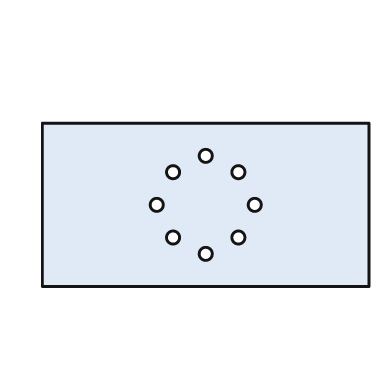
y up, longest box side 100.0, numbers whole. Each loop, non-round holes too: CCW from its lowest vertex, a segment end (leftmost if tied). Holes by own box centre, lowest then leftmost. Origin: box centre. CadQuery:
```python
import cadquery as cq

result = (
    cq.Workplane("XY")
    .moveTo(-50.0, -25.0)
    .lineTo(50.0, -25.0)
    .lineTo(50.0, 25.0)
    .lineTo(-50.0, 25.0)
    .close()
    .moveTo(0.0, -15.0)
    .circle(2.0)
    .moveTo(-10.0, -10.0)
    .circle(2.0)
    .moveTo(10.0, -10.0)
    .circle(2.0)
    .moveTo(-15.0, 0.0)
    .circle(2.0)
    .moveTo(15.0, 0.0)
    .circle(2.0)
    .moveTo(-10.0, 10.0)
    .circle(2.0)
    .moveTo(10.0, 10.0)
    .circle(2.0)
    .moveTo(0.0, 15.0)
    .circle(2.0)
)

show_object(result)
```